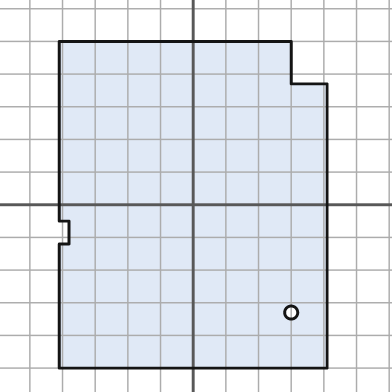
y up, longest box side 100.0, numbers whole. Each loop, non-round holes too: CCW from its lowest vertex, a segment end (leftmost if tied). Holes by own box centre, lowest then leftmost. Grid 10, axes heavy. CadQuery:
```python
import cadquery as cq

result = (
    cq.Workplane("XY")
    .moveTo(-41.0, -50.0)
    .lineTo(41.0, -50.0)
    .lineTo(41.0, 37.0)
    .lineTo(30.0, 37.0)
    .lineTo(30.0, 50.0)
    .lineTo(-41.0, 50.0)
    .lineTo(-41.0, -5.0)
    .lineTo(-38.0, -5.0)
    .lineTo(-38.0, -12.0)
    .lineTo(-41.0, -12.0)
    .close()
    .moveTo(30.0, -33.0)
    .circle(2.0)
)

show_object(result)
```